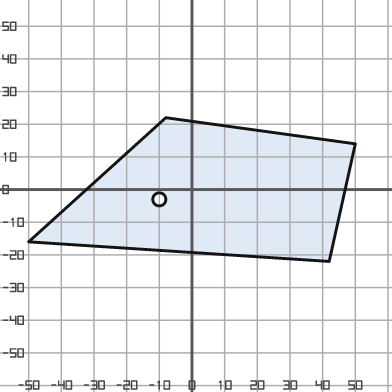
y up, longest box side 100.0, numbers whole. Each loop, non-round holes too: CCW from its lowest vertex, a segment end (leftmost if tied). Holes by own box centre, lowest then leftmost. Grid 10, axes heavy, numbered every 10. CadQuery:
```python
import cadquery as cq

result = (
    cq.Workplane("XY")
    .moveTo(42.0, -22.0)
    .lineTo(50.0, 14.0)
    .lineTo(-8.0, 22.0)
    .lineTo(-50.0, -16.0)
    .close()
    .moveTo(-10.0, -3.0)
    .circle(2.0)
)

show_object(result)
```